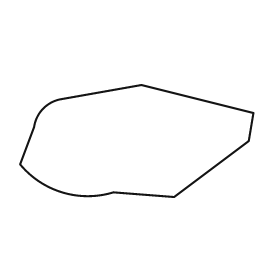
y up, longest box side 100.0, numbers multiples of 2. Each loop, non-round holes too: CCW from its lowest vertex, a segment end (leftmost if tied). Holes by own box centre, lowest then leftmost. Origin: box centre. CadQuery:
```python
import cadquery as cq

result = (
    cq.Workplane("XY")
    .moveTo(16.0, -24.0)
    .lineTo(48.0, 0.0)
    .lineTo(50.0, 12.0)
    .lineTo(2.0, 24.0)
    .lineTo(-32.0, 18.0)
    .threePointArc((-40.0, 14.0), (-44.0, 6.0))
    .lineTo(-50.0, -10.0)
    .threePointArc((-32.0, -22.0), (-10.0, -22.0))
    .close()
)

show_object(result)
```